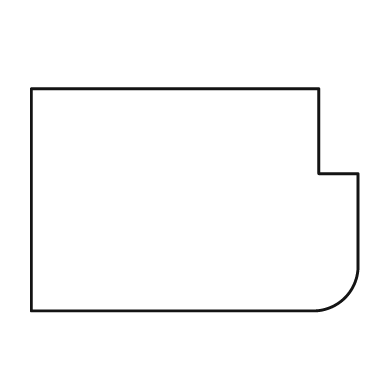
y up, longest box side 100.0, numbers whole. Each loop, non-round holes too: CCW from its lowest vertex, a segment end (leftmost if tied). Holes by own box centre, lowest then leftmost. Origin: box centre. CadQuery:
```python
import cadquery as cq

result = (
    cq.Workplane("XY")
    .moveTo(-50.0, -34.0)
    .lineTo(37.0, -34.0)
    .threePointArc((46.0, -30.0), (50.0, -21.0))
    .lineTo(50.0, 8.0)
    .lineTo(38.0, 8.0)
    .lineTo(38.0, 34.0)
    .lineTo(-50.0, 34.0)
    .close()
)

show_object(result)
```